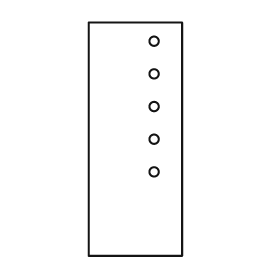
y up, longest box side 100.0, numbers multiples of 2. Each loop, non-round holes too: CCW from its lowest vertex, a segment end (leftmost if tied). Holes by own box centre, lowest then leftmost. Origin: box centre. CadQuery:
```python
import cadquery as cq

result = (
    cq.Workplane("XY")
    .moveTo(-20.0, -50.0)
    .lineTo(20.0, -50.0)
    .lineTo(20.0, 50.0)
    .lineTo(-20.0, 50.0)
    .close()
    .moveTo(8.0, -14.0)
    .circle(2.0)
    .moveTo(8.0, 0.0)
    .circle(2.0)
    .moveTo(8.0, 14.0)
    .circle(2.0)
    .moveTo(8.0, 28.0)
    .circle(2.0)
    .moveTo(8.0, 42.0)
    .circle(2.0)
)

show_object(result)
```